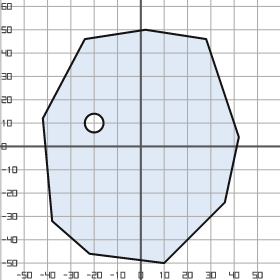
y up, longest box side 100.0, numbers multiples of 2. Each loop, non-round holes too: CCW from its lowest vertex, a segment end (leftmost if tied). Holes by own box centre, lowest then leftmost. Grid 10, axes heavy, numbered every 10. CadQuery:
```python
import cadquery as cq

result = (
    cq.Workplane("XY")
    .moveTo(10.0, -50.0)
    .lineTo(36.0, -24.0)
    .lineTo(42.0, 4.0)
    .lineTo(28.0, 46.0)
    .lineTo(2.0, 50.0)
    .lineTo(-24.0, 46.0)
    .lineTo(-42.0, 12.0)
    .lineTo(-38.0, -32.0)
    .lineTo(-22.0, -46.0)
    .close()
    .moveTo(-20.0, 10.0)
    .circle(4.0)
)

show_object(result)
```